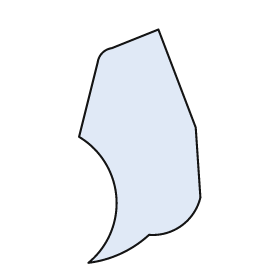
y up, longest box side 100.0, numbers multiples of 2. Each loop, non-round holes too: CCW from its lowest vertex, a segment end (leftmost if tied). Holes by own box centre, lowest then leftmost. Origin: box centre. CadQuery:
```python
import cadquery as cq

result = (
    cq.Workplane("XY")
    .moveTo(-22.0, -50.0)
    .threePointArc((-8.0, -46.0), (4.0, -38.0))
    .threePointArc((18.0, -34.0), (26.0, -22.0))
    .lineTo(24.0, 8.0)
    .lineTo(8.0, 50.0)
    .lineTo(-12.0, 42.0)
    .threePointArc((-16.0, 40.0), (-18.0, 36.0))
    .lineTo(-26.0, 4.0)
    .threePointArc((-10.0, -22.0), (-22.0, -50.0))
    .close()
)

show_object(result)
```